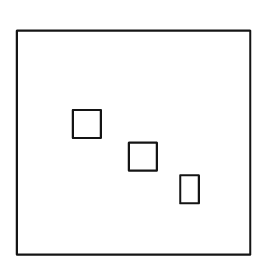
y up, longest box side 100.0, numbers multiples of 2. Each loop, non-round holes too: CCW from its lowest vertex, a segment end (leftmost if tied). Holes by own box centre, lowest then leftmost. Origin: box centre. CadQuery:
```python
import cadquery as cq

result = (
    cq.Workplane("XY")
    .moveTo(-50.0, -48.0)
    .lineTo(50.0, -48.0)
    .lineTo(50.0, 48.0)
    .lineTo(-50.0, 48.0)
    .close()
    .moveTo(20.0, -26.0)
    .lineTo(28.0, -26.0)
    .lineTo(28.0, -14.0)
    .lineTo(20.0, -14.0)
    .close()
    .moveTo(-2.0, -12.0)
    .lineTo(10.0, -12.0)
    .lineTo(10.0, 0.0)
    .lineTo(-2.0, 0.0)
    .close()
    .moveTo(-26.0, 2.0)
    .lineTo(-14.0, 2.0)
    .lineTo(-14.0, 14.0)
    .lineTo(-26.0, 14.0)
    .close()
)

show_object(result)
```